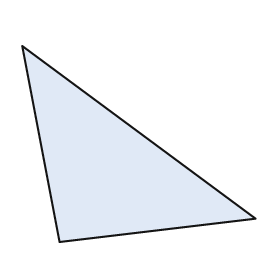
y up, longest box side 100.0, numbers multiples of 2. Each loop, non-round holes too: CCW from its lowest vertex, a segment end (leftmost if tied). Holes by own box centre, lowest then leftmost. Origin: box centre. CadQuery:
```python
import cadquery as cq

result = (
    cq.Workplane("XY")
    .moveTo(-34.0, -42.0)
    .lineTo(50.0, -32.0)
    .lineTo(-50.0, 42.0)
    .close()
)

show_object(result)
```